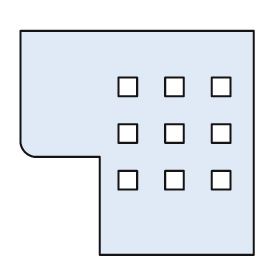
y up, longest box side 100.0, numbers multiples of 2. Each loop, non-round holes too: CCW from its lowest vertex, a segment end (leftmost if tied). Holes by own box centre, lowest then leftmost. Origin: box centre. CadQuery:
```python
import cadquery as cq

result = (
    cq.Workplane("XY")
    .moveTo(-16.0, -48.0)
    .lineTo(50.0, -48.0)
    .lineTo(50.0, 48.0)
    .lineTo(-50.0, 48.0)
    .lineTo(-50.0, 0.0)
    .threePointArc((-48.0, -4.0), (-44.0, -6.0))
    .lineTo(-16.0, -6.0)
    .close()
    .moveTo(-8.0, -20.0)
    .lineTo(0.0, -20.0)
    .lineTo(0.0, -12.0)
    .lineTo(-8.0, -12.0)
    .close()
    .moveTo(12.0, -20.0)
    .lineTo(20.0, -20.0)
    .lineTo(20.0, -12.0)
    .lineTo(12.0, -12.0)
    .close()
    .moveTo(32.0, -20.0)
    .lineTo(40.0, -20.0)
    .lineTo(40.0, -12.0)
    .lineTo(32.0, -12.0)
    .close()
    .moveTo(-8.0, 0.0)
    .lineTo(0.0, 0.0)
    .lineTo(0.0, 8.0)
    .lineTo(-8.0, 8.0)
    .close()
    .moveTo(12.0, 0.0)
    .lineTo(20.0, 0.0)
    .lineTo(20.0, 8.0)
    .lineTo(12.0, 8.0)
    .close()
    .moveTo(32.0, 0.0)
    .lineTo(40.0, 0.0)
    .lineTo(40.0, 8.0)
    .lineTo(32.0, 8.0)
    .close()
    .moveTo(-8.0, 20.0)
    .lineTo(0.0, 20.0)
    .lineTo(0.0, 28.0)
    .lineTo(-8.0, 28.0)
    .close()
    .moveTo(12.0, 20.0)
    .lineTo(20.0, 20.0)
    .lineTo(20.0, 28.0)
    .lineTo(12.0, 28.0)
    .close()
    .moveTo(32.0, 20.0)
    .lineTo(40.0, 20.0)
    .lineTo(40.0, 28.0)
    .lineTo(32.0, 28.0)
    .close()
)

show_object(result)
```